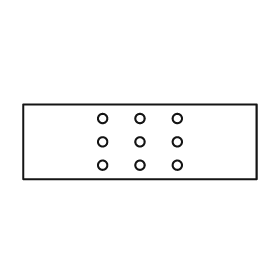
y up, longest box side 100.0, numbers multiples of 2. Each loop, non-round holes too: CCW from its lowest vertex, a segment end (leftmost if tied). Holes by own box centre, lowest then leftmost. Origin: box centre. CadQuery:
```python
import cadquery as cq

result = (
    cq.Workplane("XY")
    .moveTo(-50.0, -16.0)
    .lineTo(50.0, -16.0)
    .lineTo(50.0, 16.0)
    .lineTo(-50.0, 16.0)
    .close()
    .moveTo(-16.0, -10.0)
    .circle(2.0)
    .moveTo(0.0, -10.0)
    .circle(2.0)
    .moveTo(16.0, -10.0)
    .circle(2.0)
    .moveTo(-16.0, 0.0)
    .circle(2.0)
    .moveTo(0.0, 0.0)
    .circle(2.0)
    .moveTo(16.0, 0.0)
    .circle(2.0)
    .moveTo(-16.0, 10.0)
    .circle(2.0)
    .moveTo(0.0, 10.0)
    .circle(2.0)
    .moveTo(16.0, 10.0)
    .circle(2.0)
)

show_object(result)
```